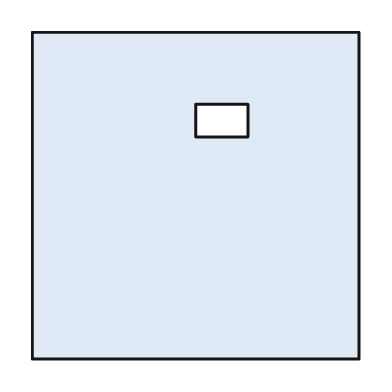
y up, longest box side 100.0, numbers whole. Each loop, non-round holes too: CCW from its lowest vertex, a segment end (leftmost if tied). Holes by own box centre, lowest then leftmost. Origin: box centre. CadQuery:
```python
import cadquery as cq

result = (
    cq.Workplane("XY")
    .moveTo(-50.0, -50.0)
    .lineTo(50.0, -50.0)
    .lineTo(50.0, 50.0)
    .lineTo(-50.0, 50.0)
    .close()
    .moveTo(0.0, 18.0)
    .lineTo(16.0, 18.0)
    .lineTo(16.0, 28.0)
    .lineTo(0.0, 28.0)
    .close()
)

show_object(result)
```